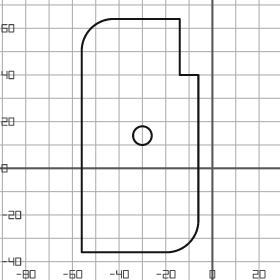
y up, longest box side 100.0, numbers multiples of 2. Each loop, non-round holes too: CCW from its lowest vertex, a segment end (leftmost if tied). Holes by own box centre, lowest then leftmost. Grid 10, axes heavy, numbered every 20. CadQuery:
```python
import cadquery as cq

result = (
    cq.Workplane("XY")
    .moveTo(-56.0, -36.0)
    .lineTo(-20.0, -36.0)
    .threePointArc((-10.0, -32.0), (-6.0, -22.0))
    .lineTo(-6.0, 40.0)
    .lineTo(-14.0, 40.0)
    .lineTo(-14.0, 64.0)
    .lineTo(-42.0, 64.0)
    .threePointArc((-52.0, 60.0), (-56.0, 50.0))
    .close()
    .moveTo(-30.0, 14.0)
    .circle(4.0)
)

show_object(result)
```